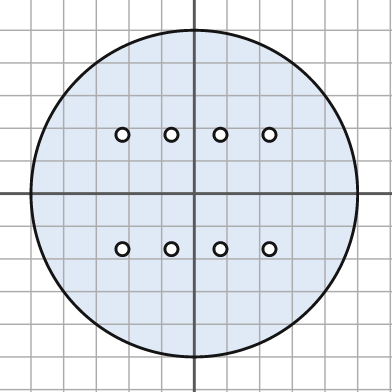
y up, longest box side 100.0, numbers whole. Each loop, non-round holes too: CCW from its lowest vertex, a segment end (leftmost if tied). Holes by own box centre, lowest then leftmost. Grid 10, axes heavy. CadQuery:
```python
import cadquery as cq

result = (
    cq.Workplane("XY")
    .moveTo(0.0, 0.0)
    .circle(50.0)
    .moveTo(-22.0, -17.0)
    .circle(2.0)
    .moveTo(-7.0, -17.0)
    .circle(2.0)
    .moveTo(8.0, -17.0)
    .circle(2.0)
    .moveTo(23.0, -17.0)
    .circle(2.0)
    .moveTo(-22.0, 18.0)
    .circle(2.0)
    .moveTo(-7.0, 18.0)
    .circle(2.0)
    .moveTo(8.0, 18.0)
    .circle(2.0)
    .moveTo(23.0, 18.0)
    .circle(2.0)
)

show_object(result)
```